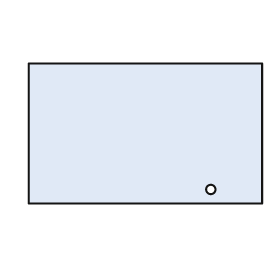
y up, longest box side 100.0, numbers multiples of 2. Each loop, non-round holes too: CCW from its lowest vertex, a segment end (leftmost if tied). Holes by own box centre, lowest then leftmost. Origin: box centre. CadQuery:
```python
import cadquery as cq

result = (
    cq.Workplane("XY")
    .moveTo(-50.0, -30.0)
    .lineTo(50.0, -30.0)
    .lineTo(50.0, 30.0)
    .lineTo(-50.0, 30.0)
    .close()
    .moveTo(28.0, -24.0)
    .circle(2.0)
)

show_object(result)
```